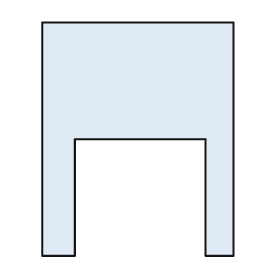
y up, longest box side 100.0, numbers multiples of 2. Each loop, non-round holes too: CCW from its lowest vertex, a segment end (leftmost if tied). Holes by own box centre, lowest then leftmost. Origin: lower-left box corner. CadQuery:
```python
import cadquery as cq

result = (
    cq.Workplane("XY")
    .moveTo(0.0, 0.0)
    .lineTo(14.0, 0.0)
    .lineTo(14.0, 50.0)
    .lineTo(70.0, 50.0)
    .lineTo(70.0, 0.0)
    .lineTo(82.0, 0.0)
    .lineTo(82.0, 100.0)
    .lineTo(0.0, 100.0)
    .close()
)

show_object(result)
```